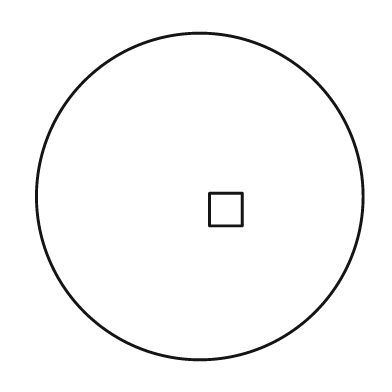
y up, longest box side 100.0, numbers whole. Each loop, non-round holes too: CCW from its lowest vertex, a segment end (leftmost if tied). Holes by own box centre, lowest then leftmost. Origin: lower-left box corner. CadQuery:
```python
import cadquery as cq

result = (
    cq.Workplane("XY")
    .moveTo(50.0, 50.0)
    .circle(50.0)
    .moveTo(53.0, 41.0)
    .lineTo(63.0, 41.0)
    .lineTo(63.0, 51.0)
    .lineTo(53.0, 51.0)
    .close()
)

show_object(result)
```